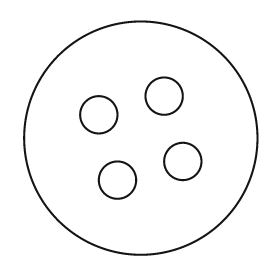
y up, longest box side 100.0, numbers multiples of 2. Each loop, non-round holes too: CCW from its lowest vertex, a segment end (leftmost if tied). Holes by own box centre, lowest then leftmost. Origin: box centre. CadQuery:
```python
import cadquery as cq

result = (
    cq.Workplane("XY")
    .moveTo(0.0, 0.0)
    .circle(50.0)
    .moveTo(-10.0, -18.0)
    .circle(8.0)
    .moveTo(18.0, -10.0)
    .circle(8.0)
    .moveTo(-18.0, 10.0)
    .circle(8.0)
    .moveTo(10.0, 18.0)
    .circle(8.0)
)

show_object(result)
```